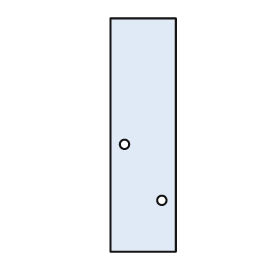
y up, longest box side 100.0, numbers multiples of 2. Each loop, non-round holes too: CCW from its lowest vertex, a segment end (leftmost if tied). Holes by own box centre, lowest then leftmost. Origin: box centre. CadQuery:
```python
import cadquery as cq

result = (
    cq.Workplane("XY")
    .moveTo(-14.0, -50.0)
    .lineTo(14.0, -50.0)
    .lineTo(14.0, 50.0)
    .lineTo(-14.0, 50.0)
    .close()
    .moveTo(8.0, -28.0)
    .circle(2.0)
    .moveTo(-8.0, -4.0)
    .circle(2.0)
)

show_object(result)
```